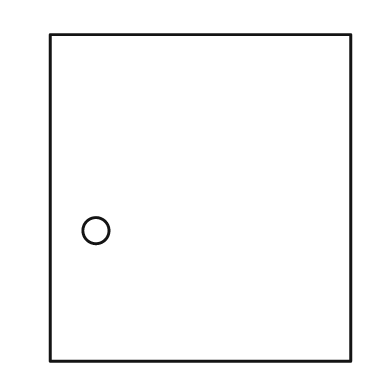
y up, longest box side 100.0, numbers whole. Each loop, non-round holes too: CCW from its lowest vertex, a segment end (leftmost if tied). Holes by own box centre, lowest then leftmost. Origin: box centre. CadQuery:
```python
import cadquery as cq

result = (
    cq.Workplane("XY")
    .moveTo(-46.0, -50.0)
    .lineTo(46.0, -50.0)
    .lineTo(46.0, 50.0)
    .lineTo(-46.0, 50.0)
    .close()
    .moveTo(-32.0, -10.0)
    .circle(4.0)
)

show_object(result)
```